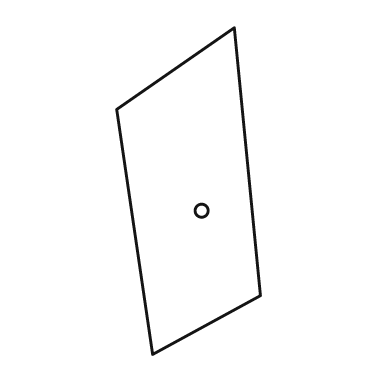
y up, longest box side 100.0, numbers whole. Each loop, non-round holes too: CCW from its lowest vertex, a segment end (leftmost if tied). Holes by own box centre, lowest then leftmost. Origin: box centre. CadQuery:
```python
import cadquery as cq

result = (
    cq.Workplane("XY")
    .moveTo(-11.0, -50.0)
    .lineTo(22.0, -32.0)
    .lineTo(14.0, 50.0)
    .lineTo(-22.0, 25.0)
    .close()
    .moveTo(4.0, -6.0)
    .circle(2.0)
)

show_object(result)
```